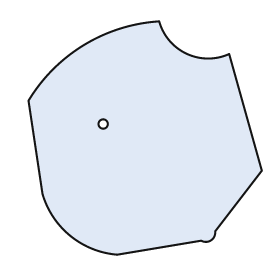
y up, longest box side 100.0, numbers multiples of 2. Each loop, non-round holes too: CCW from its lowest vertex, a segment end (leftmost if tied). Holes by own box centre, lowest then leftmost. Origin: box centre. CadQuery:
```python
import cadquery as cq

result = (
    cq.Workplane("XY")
    .moveTo(-12.0, -50.0)
    .lineTo(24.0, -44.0)
    .threePointArc((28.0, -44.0), (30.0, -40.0))
    .lineTo(50.0, -14.0)
    .lineTo(36.0, 36.0)
    .threePointArc((18.0, 36.0), (6.0, 50.0))
    .threePointArc((-26.0, 40.0), (-50.0, 16.0))
    .lineTo(-44.0, -24.0)
    .threePointArc((-32.0, -42.0), (-12.0, -50.0))
    .close()
    .moveTo(-18.0, 6.0)
    .circle(2.0)
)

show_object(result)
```